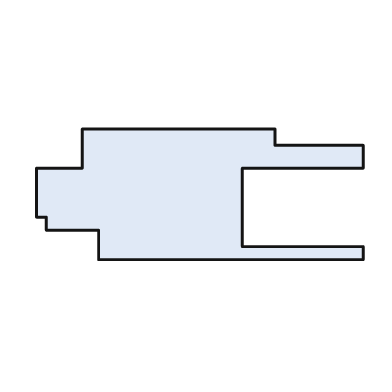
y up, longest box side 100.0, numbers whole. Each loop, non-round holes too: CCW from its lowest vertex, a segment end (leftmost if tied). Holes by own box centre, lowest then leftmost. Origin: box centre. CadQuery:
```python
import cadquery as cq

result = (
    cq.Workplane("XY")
    .moveTo(-31.0, -20.0)
    .lineTo(50.0, -20.0)
    .lineTo(50.0, -16.0)
    .lineTo(13.0, -16.0)
    .lineTo(13.0, 8.0)
    .lineTo(50.0, 8.0)
    .lineTo(50.0, 15.0)
    .lineTo(23.0, 15.0)
    .lineTo(23.0, 20.0)
    .lineTo(-36.0, 20.0)
    .lineTo(-36.0, 8.0)
    .lineTo(-50.0, 8.0)
    .lineTo(-50.0, -7.0)
    .lineTo(-47.0, -7.0)
    .lineTo(-47.0, -11.0)
    .lineTo(-31.0, -11.0)
    .close()
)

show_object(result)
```